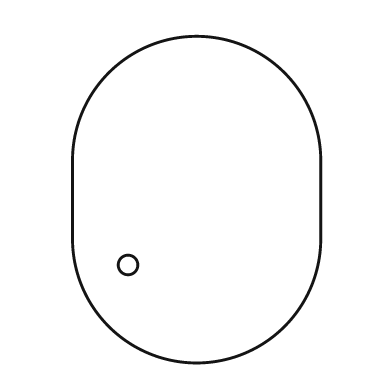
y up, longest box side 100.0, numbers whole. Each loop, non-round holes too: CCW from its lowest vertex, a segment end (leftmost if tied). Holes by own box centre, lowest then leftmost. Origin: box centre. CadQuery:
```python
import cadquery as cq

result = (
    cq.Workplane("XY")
    .moveTo(-38.0, -12.0)
    .threePointArc((0.0, -50.0), (38.0, -12.0))
    .lineTo(38.0, 12.0)
    .threePointArc((0.0, 50.0), (-38.0, 12.0))
    .close()
    .moveTo(-21.0, -20.0)
    .circle(3.0)
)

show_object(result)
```